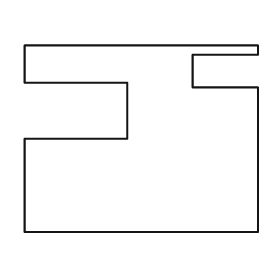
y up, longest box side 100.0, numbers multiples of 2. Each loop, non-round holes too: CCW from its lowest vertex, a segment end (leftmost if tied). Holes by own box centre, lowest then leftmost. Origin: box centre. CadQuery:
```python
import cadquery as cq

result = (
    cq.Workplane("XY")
    .moveTo(-50.0, -40.0)
    .lineTo(50.0, -40.0)
    .lineTo(50.0, 22.0)
    .lineTo(22.0, 22.0)
    .lineTo(22.0, 36.0)
    .lineTo(50.0, 36.0)
    .lineTo(50.0, 40.0)
    .lineTo(-50.0, 40.0)
    .lineTo(-50.0, 24.0)
    .lineTo(-6.0, 24.0)
    .lineTo(-6.0, 0.0)
    .lineTo(-50.0, 0.0)
    .close()
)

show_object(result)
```